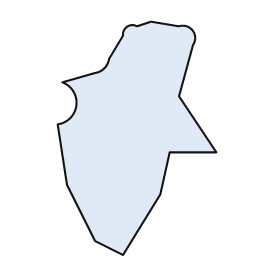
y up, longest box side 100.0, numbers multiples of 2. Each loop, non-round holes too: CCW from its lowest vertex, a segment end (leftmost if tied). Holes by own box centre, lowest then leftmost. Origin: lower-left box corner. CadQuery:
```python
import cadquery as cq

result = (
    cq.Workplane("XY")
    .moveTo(28.0, 0.0)
    .lineTo(44.0, 26.0)
    .lineTo(48.0, 44.0)
    .lineTo(68.0, 44.0)
    .lineTo(52.0, 68.0)
    .lineTo(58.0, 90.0)
    .threePointArc((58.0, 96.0), (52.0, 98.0))
    .lineTo(40.0, 100.0)
    .lineTo(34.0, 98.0)
    .threePointArc((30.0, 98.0), (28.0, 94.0))
    .lineTo(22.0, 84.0)
    .threePointArc((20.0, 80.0), (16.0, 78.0))
    .lineTo(2.0, 74.0)
    .threePointArc((8.0, 64.0), (0.0, 56.0))
    .lineTo(4.0, 30.0)
    .lineTo(16.0, 6.0)
    .close()
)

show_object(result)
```